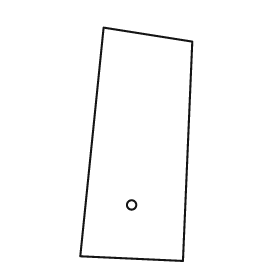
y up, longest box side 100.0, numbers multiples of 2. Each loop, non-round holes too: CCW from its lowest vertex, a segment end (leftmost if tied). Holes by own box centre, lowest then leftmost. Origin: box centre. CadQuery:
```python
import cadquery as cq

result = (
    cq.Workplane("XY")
    .moveTo(20.0, -50.0)
    .lineTo(24.0, 44.0)
    .lineTo(-14.0, 50.0)
    .lineTo(-24.0, -48.0)
    .close()
    .moveTo(-2.0, -26.0)
    .circle(2.0)
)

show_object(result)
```